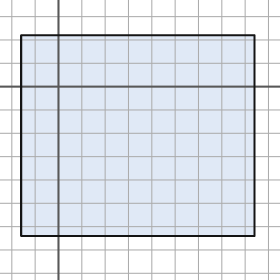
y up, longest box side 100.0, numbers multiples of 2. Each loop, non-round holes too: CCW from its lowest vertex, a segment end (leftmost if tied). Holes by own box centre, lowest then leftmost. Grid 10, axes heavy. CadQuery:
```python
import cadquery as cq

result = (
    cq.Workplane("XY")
    .moveTo(-16.0, -64.0)
    .lineTo(84.0, -64.0)
    .lineTo(84.0, 22.0)
    .lineTo(-16.0, 22.0)
    .close()
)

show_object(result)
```